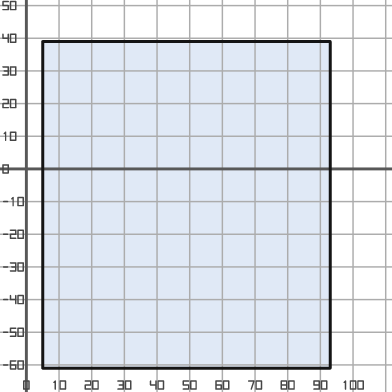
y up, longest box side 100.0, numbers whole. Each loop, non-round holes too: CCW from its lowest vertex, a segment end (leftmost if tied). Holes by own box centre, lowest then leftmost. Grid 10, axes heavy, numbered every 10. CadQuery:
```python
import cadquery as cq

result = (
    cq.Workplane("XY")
    .moveTo(5.0, -61.0)
    .lineTo(93.0, -61.0)
    .lineTo(93.0, 39.0)
    .lineTo(5.0, 39.0)
    .close()
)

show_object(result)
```